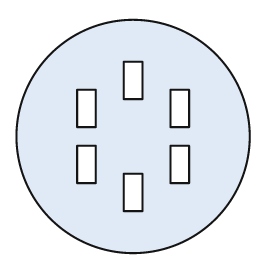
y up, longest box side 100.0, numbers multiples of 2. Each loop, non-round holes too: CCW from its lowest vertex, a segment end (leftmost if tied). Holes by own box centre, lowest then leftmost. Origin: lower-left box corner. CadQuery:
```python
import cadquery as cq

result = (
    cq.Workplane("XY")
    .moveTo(50.0, 50.0)
    .circle(50.0)
    .moveTo(46.0, 18.0)
    .lineTo(54.0, 18.0)
    .lineTo(54.0, 34.0)
    .lineTo(46.0, 34.0)
    .close()
    .moveTo(26.0, 30.0)
    .lineTo(34.0, 30.0)
    .lineTo(34.0, 46.0)
    .lineTo(26.0, 46.0)
    .close()
    .moveTo(66.0, 30.0)
    .lineTo(74.0, 30.0)
    .lineTo(74.0, 46.0)
    .lineTo(66.0, 46.0)
    .close()
    .moveTo(26.0, 54.0)
    .lineTo(34.0, 54.0)
    .lineTo(34.0, 70.0)
    .lineTo(26.0, 70.0)
    .close()
    .moveTo(66.0, 54.0)
    .lineTo(74.0, 54.0)
    .lineTo(74.0, 70.0)
    .lineTo(66.0, 70.0)
    .close()
    .moveTo(46.0, 66.0)
    .lineTo(54.0, 66.0)
    .lineTo(54.0, 82.0)
    .lineTo(46.0, 82.0)
    .close()
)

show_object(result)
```